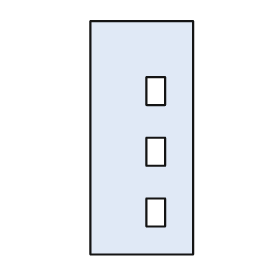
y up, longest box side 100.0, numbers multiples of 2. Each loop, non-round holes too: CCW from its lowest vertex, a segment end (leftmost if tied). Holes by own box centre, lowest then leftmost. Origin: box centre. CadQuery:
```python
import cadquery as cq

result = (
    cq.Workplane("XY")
    .moveTo(-22.0, -50.0)
    .lineTo(22.0, -50.0)
    .lineTo(22.0, 50.0)
    .lineTo(-22.0, 50.0)
    .close()
    .moveTo(2.0, -38.0)
    .lineTo(10.0, -38.0)
    .lineTo(10.0, -26.0)
    .lineTo(2.0, -26.0)
    .close()
    .moveTo(2.0, -12.0)
    .lineTo(10.0, -12.0)
    .lineTo(10.0, 0.0)
    .lineTo(2.0, 0.0)
    .close()
    .moveTo(2.0, 14.0)
    .lineTo(10.0, 14.0)
    .lineTo(10.0, 26.0)
    .lineTo(2.0, 26.0)
    .close()
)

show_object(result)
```